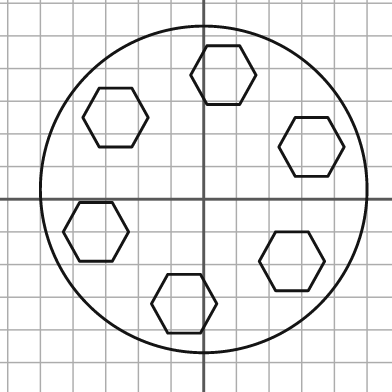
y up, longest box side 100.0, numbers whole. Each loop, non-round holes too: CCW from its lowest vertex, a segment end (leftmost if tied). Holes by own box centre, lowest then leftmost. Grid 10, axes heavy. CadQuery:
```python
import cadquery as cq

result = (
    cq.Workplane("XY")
    .moveTo(0.0, 3.0)
    .circle(50.0)
    .moveTo(-11.0, -41.0)
    .lineTo(-1.0, -41.0)
    .lineTo(4.0, -32.0)
    .lineTo(-1.0, -23.0)
    .lineTo(-11.0, -23.0)
    .lineTo(-16.0, -32.0)
    .close()
    .moveTo(22.0, -28.0)
    .lineTo(32.0, -28.0)
    .lineTo(37.0, -19.0)
    .lineTo(32.0, -10.0)
    .lineTo(22.0, -10.0)
    .lineTo(17.0, -19.0)
    .close()
    .moveTo(-38.0, -19.0)
    .lineTo(-28.0, -19.0)
    .lineTo(-23.0, -10.0)
    .lineTo(-28.0, -1.0)
    .lineTo(-38.0, -1.0)
    .lineTo(-43.0, -10.0)
    .close()
    .moveTo(28.0, 7.0)
    .lineTo(38.0, 7.0)
    .lineTo(43.0, 16.0)
    .lineTo(38.0, 25.0)
    .lineTo(28.0, 25.0)
    .lineTo(23.0, 16.0)
    .close()
    .moveTo(-32.0, 16.0)
    .lineTo(-22.0, 16.0)
    .lineTo(-17.0, 25.0)
    .lineTo(-22.0, 34.0)
    .lineTo(-32.0, 34.0)
    .lineTo(-37.0, 25.0)
    .close()
    .moveTo(1.0, 29.0)
    .lineTo(11.0, 29.0)
    .lineTo(16.0, 38.0)
    .lineTo(11.0, 47.0)
    .lineTo(1.0, 47.0)
    .lineTo(-4.0, 38.0)
    .close()
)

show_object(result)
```